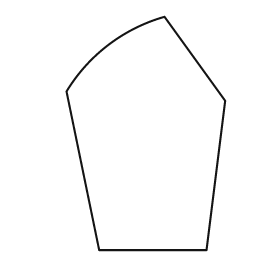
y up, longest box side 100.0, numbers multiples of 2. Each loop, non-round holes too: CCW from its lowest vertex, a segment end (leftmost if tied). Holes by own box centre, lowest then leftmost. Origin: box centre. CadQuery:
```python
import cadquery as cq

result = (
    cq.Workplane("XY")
    .moveTo(-20.0, -50.0)
    .lineTo(26.0, -50.0)
    .lineTo(34.0, 14.0)
    .lineTo(8.0, 50.0)
    .threePointArc((-16.0, 38.0), (-34.0, 18.0))
    .close()
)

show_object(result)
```